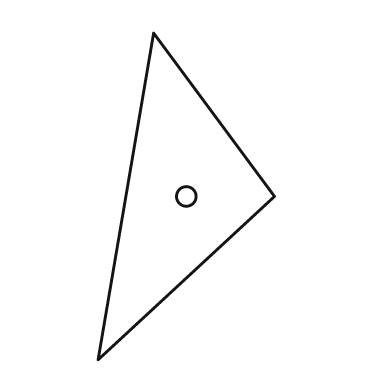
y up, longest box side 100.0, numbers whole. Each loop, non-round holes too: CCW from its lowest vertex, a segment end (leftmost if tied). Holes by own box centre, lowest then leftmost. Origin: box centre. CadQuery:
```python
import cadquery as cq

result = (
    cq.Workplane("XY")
    .moveTo(-27.0, -50.0)
    .lineTo(27.0, 0.0)
    .lineTo(-10.0, 50.0)
    .close()
    .moveTo(0.0, 0.0)
    .circle(3.0)
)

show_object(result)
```